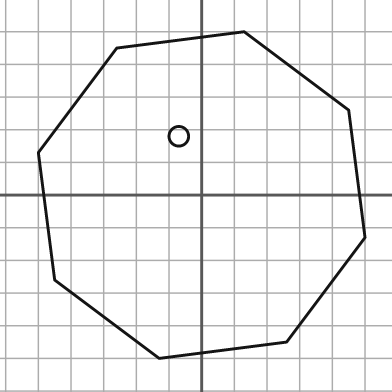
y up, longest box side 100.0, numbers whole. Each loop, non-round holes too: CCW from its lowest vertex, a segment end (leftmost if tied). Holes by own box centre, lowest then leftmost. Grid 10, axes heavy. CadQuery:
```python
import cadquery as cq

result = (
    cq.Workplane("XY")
    .moveTo(-13.0, -50.0)
    .lineTo(26.0, -45.0)
    .lineTo(50.0, -13.0)
    .lineTo(45.0, 26.0)
    .lineTo(13.0, 50.0)
    .lineTo(-26.0, 45.0)
    .lineTo(-50.0, 13.0)
    .lineTo(-45.0, -26.0)
    .close()
    .moveTo(-7.0, 18.0)
    .circle(3.0)
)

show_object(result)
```